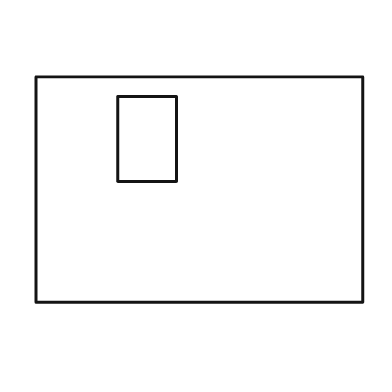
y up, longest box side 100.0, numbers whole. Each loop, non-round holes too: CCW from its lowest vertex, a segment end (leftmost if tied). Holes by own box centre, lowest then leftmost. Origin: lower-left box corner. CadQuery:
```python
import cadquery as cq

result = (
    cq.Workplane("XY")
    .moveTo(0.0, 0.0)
    .lineTo(100.0, 0.0)
    .lineTo(100.0, 69.0)
    .lineTo(0.0, 69.0)
    .close()
    .moveTo(25.0, 37.0)
    .lineTo(43.0, 37.0)
    .lineTo(43.0, 63.0)
    .lineTo(25.0, 63.0)
    .close()
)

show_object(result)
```